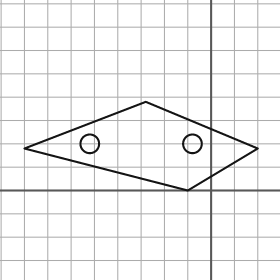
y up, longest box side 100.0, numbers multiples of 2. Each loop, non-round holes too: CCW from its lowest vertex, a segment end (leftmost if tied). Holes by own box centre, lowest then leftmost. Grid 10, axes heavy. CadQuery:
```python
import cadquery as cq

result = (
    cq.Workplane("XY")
    .moveTo(-10.0, 0.0)
    .lineTo(20.0, 18.0)
    .lineTo(-28.0, 38.0)
    .lineTo(-80.0, 18.0)
    .close()
    .moveTo(-52.0, 20.0)
    .circle(4.0)
    .moveTo(-8.0, 20.0)
    .circle(4.0)
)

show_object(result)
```